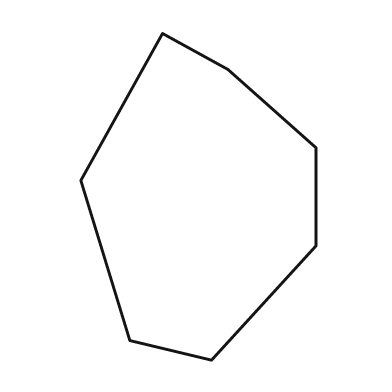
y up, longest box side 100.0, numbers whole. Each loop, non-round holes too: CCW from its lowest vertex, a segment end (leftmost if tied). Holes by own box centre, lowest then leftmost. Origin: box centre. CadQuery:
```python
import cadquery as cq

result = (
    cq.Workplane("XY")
    .moveTo(4.0, -50.0)
    .lineTo(36.0, -15.0)
    .lineTo(36.0, 15.0)
    .lineTo(9.0, 39.0)
    .lineTo(-11.0, 50.0)
    .lineTo(-36.0, 5.0)
    .lineTo(-21.0, -44.0)
    .close()
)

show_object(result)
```